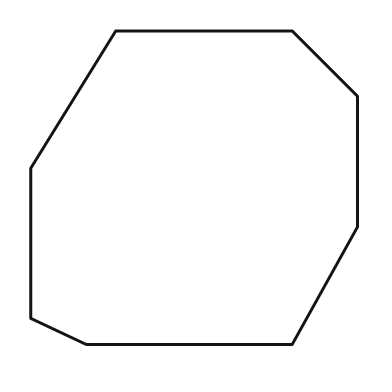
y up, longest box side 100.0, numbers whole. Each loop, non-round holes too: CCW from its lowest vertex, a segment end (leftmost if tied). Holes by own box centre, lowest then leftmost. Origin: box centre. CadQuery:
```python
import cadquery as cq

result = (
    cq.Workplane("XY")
    .moveTo(-33.0, -48.0)
    .lineTo(30.0, -48.0)
    .lineTo(50.0, -12.0)
    .lineTo(50.0, 28.0)
    .lineTo(30.0, 48.0)
    .lineTo(-24.0, 48.0)
    .lineTo(-50.0, 6.0)
    .lineTo(-50.0, -40.0)
    .close()
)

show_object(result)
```